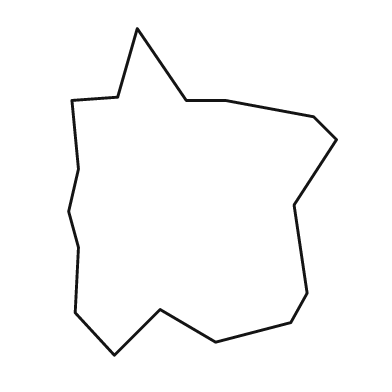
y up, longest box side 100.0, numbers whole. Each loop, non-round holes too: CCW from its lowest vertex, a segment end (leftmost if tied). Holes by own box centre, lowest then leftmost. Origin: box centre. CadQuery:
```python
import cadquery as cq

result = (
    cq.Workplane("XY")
    .moveTo(-27.0, -50.0)
    .lineTo(-13.0, -36.0)
    .lineTo(4.0, -46.0)
    .lineTo(27.0, -40.0)
    .lineTo(32.0, -31.0)
    .lineTo(28.0, -4.0)
    .lineTo(41.0, 16.0)
    .lineTo(34.0, 23.0)
    .lineTo(7.0, 28.0)
    .lineTo(-5.0, 28.0)
    .lineTo(-20.0, 50.0)
    .lineTo(-26.0, 29.0)
    .lineTo(-40.0, 28.0)
    .lineTo(-38.0, 7.0)
    .lineTo(-41.0, -6.0)
    .lineTo(-38.0, -17.0)
    .lineTo(-39.0, -37.0)
    .close()
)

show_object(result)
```